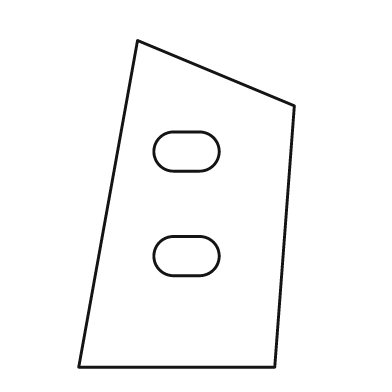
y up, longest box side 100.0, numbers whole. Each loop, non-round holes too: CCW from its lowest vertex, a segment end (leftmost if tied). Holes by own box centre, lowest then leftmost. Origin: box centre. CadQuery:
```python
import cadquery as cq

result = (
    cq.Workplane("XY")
    .moveTo(-33.0, -50.0)
    .lineTo(27.0, -50.0)
    .lineTo(33.0, 30.0)
    .lineTo(-15.0, 50.0)
    .close()
    .moveTo(-4.0, -22.0)
    .lineTo(4.0, -22.0)
    .threePointArc((10.0, -16.0), (4.0, -10.0))
    .lineTo(-4.0, -10.0)
    .threePointArc((-10.0, -16.0), (-4.0, -22.0))
    .close()
    .moveTo(-4.0, 10.0)
    .lineTo(4.0, 10.0)
    .threePointArc((10.0, 16.0), (4.0, 22.0))
    .lineTo(-4.0, 22.0)
    .threePointArc((-10.0, 16.0), (-4.0, 10.0))
    .close()
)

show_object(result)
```